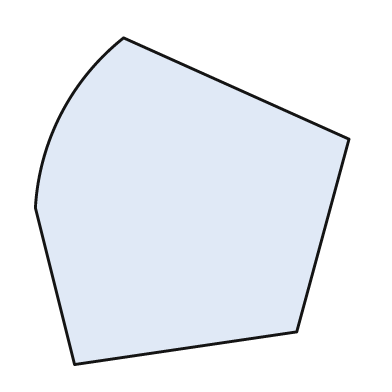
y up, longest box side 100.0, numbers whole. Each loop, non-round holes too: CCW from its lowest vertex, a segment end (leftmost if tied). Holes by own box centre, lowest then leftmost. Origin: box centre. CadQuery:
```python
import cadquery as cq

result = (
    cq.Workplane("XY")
    .moveTo(-36.0, -50.0)
    .lineTo(32.0, -40.0)
    .lineTo(48.0, 19.0)
    .lineTo(-21.0, 50.0)
    .threePointArc((-40.0, 27.0), (-48.0, -2.0))
    .close()
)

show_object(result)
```